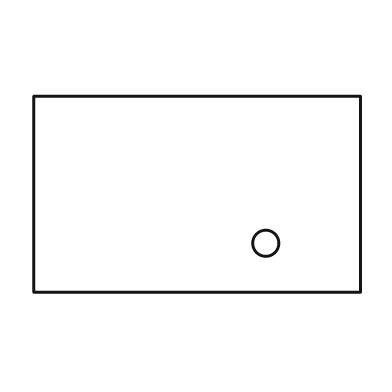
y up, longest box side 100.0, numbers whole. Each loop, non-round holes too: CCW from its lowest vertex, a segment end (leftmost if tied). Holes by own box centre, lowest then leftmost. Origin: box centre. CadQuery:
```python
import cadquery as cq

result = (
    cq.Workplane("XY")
    .moveTo(-50.0, -30.0)
    .lineTo(50.0, -30.0)
    .lineTo(50.0, 30.0)
    .lineTo(-50.0, 30.0)
    .close()
    .moveTo(21.0, -15.0)
    .circle(4.0)
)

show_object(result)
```